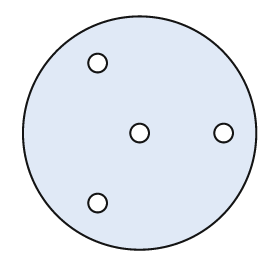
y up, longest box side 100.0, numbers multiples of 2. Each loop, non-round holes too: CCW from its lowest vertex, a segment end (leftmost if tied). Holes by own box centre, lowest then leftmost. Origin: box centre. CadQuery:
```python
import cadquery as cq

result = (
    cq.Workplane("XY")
    .moveTo(0.0, 0.0)
    .circle(50.0)
    .moveTo(-18.0, -30.0)
    .circle(4.0)
    .moveTo(0.0, 0.0)
    .circle(4.0)
    .moveTo(36.0, 0.0)
    .circle(4.0)
    .moveTo(-18.0, 30.0)
    .circle(4.0)
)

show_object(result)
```